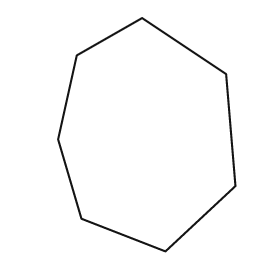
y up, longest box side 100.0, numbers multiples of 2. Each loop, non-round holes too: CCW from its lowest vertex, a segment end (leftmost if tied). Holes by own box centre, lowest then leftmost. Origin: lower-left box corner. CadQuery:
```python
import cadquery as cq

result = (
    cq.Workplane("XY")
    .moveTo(46.0, 0.0)
    .lineTo(76.0, 28.0)
    .lineTo(72.0, 76.0)
    .lineTo(36.0, 100.0)
    .lineTo(8.0, 84.0)
    .lineTo(0.0, 48.0)
    .lineTo(10.0, 14.0)
    .close()
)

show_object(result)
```